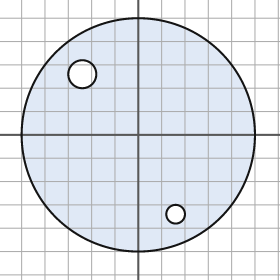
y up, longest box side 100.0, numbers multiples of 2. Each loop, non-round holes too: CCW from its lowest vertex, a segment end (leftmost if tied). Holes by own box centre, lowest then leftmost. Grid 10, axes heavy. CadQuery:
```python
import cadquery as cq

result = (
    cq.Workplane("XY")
    .moveTo(0.0, 0.0)
    .circle(50.0)
    .moveTo(16.0, -34.0)
    .circle(4.0)
    .moveTo(-24.0, 26.0)
    .circle(6.0)
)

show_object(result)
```